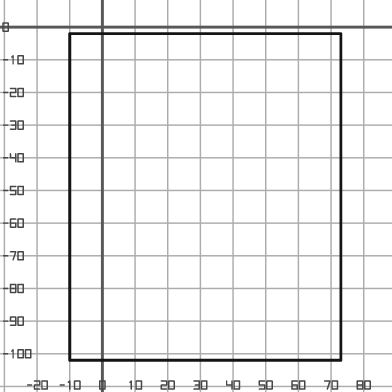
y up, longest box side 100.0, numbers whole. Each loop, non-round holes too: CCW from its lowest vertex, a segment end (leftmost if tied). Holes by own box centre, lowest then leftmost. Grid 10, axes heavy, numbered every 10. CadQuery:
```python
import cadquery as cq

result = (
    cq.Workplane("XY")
    .moveTo(-10.0, -102.0)
    .lineTo(73.0, -102.0)
    .lineTo(73.0, -2.0)
    .lineTo(-10.0, -2.0)
    .close()
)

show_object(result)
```